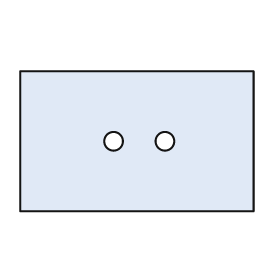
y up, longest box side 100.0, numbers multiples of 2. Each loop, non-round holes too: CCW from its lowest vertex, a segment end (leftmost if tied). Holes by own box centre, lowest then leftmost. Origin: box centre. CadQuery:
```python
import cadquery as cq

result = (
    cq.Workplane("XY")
    .moveTo(-50.0, -30.0)
    .lineTo(50.0, -30.0)
    .lineTo(50.0, 30.0)
    .lineTo(-50.0, 30.0)
    .close()
    .moveTo(-10.0, 0.0)
    .circle(4.0)
    .moveTo(12.0, 0.0)
    .circle(4.0)
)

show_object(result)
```